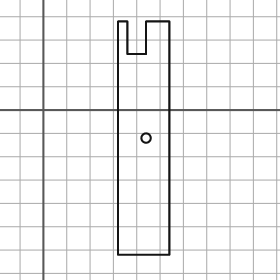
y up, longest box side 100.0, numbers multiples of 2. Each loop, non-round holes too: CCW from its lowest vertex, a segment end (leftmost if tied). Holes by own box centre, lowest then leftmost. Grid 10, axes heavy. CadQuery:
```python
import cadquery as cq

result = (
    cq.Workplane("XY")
    .moveTo(32.0, -62.0)
    .lineTo(54.0, -62.0)
    .lineTo(54.0, 38.0)
    .lineTo(44.0, 38.0)
    .lineTo(44.0, 24.0)
    .lineTo(36.0, 24.0)
    .lineTo(36.0, 38.0)
    .lineTo(32.0, 38.0)
    .close()
    .moveTo(44.0, -12.0)
    .circle(2.0)
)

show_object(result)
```